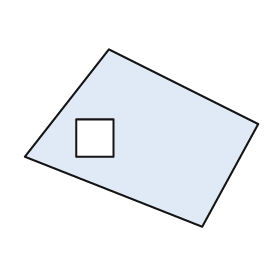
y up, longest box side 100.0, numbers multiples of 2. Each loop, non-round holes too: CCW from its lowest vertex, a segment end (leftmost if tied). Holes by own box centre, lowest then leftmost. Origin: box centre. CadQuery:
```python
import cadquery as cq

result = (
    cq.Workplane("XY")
    .moveTo(26.0, -38.0)
    .lineTo(50.0, 6.0)
    .lineTo(-14.0, 38.0)
    .lineTo(-50.0, -8.0)
    .close()
    .moveTo(-28.0, -8.0)
    .lineTo(-12.0, -8.0)
    .lineTo(-12.0, 8.0)
    .lineTo(-28.0, 8.0)
    .close()
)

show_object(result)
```